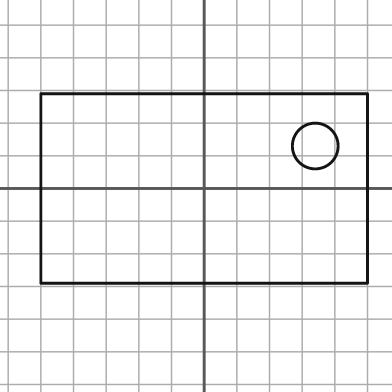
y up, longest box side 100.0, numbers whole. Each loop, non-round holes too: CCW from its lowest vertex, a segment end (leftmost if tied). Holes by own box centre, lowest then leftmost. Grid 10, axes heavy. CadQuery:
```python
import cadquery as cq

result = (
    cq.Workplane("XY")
    .moveTo(-50.0, -29.0)
    .lineTo(50.0, -29.0)
    .lineTo(50.0, 29.0)
    .lineTo(-50.0, 29.0)
    .close()
    .moveTo(34.0, 13.0)
    .circle(7.0)
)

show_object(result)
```